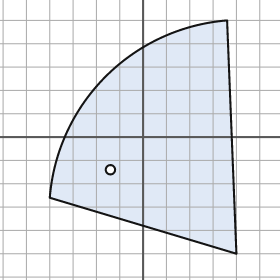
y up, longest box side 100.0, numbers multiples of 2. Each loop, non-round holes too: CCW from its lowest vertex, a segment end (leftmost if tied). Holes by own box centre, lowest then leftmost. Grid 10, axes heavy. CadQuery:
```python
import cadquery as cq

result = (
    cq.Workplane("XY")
    .moveTo(40.0, -50.0)
    .lineTo(36.0, 50.0)
    .threePointArc((-16.0, 26.0), (-40.0, -26.0))
    .close()
    .moveTo(-14.0, -14.0)
    .circle(2.0)
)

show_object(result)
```